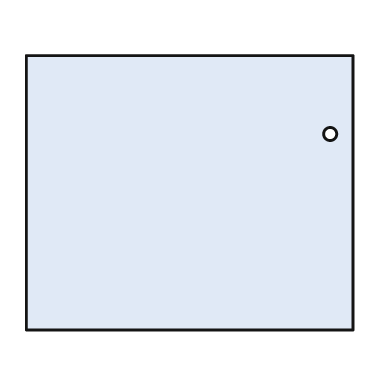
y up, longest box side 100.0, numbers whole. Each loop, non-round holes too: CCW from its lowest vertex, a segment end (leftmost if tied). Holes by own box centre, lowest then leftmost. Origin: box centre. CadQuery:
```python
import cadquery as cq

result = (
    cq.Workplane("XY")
    .moveTo(-50.0, -42.0)
    .lineTo(50.0, -42.0)
    .lineTo(50.0, 42.0)
    .lineTo(-50.0, 42.0)
    .close()
    .moveTo(43.0, 18.0)
    .circle(2.0)
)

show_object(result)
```